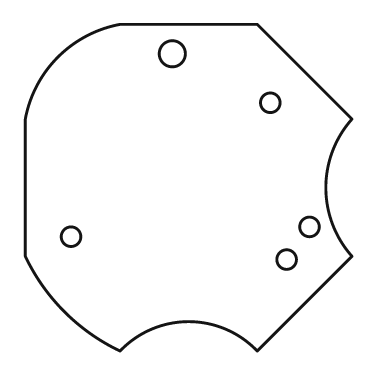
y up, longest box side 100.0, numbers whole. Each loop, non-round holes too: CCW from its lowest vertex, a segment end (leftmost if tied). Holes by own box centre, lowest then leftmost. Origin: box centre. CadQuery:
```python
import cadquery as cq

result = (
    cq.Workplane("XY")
    .moveTo(-21.0, -50.0)
    .threePointArc((0.0, -41.0), (21.0, -50.0))
    .lineTo(50.0, -21.0)
    .threePointArc((42.0, 0.0), (50.0, 21.0))
    .lineTo(21.0, 50.0)
    .lineTo(-21.0, 50.0)
    .threePointArc((-40.0, 40.0), (-50.0, 21.0))
    .lineTo(-50.0, -21.0)
    .threePointArc((-38.0, -38.0), (-21.0, -50.0))
    .close()
    .moveTo(30.0, -22.0)
    .circle(3.0)
    .moveTo(-36.0, -15.0)
    .circle(3.0)
    .moveTo(37.0, -12.0)
    .circle(3.0)
    .moveTo(25.0, 26.0)
    .circle(3.0)
    .moveTo(-5.0, 41.0)
    .circle(4.0)
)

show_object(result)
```